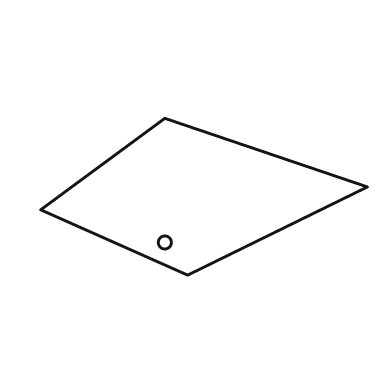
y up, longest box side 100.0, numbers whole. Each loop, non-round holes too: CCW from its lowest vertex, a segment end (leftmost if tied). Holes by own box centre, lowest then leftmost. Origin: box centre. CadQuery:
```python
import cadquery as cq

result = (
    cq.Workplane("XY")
    .moveTo(-5.0, -24.0)
    .lineTo(50.0, 3.0)
    .lineTo(-12.0, 24.0)
    .lineTo(-50.0, -4.0)
    .close()
    .moveTo(-12.0, -14.0)
    .circle(2.0)
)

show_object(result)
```